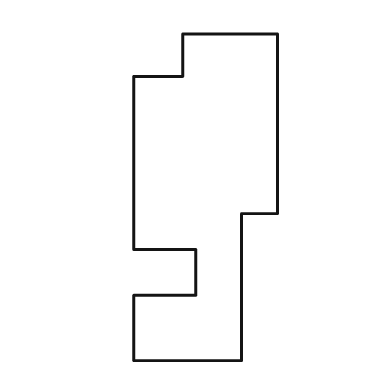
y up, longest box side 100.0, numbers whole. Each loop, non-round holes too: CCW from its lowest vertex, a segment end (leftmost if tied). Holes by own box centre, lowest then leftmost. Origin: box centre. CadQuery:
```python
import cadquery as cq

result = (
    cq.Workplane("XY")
    .moveTo(-22.0, -50.0)
    .lineTo(11.0, -50.0)
    .lineTo(11.0, -5.0)
    .lineTo(22.0, -5.0)
    .lineTo(22.0, 50.0)
    .lineTo(-7.0, 50.0)
    .lineTo(-7.0, 37.0)
    .lineTo(-22.0, 37.0)
    .lineTo(-22.0, -16.0)
    .lineTo(-3.0, -16.0)
    .lineTo(-3.0, -30.0)
    .lineTo(-22.0, -30.0)
    .close()
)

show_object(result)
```